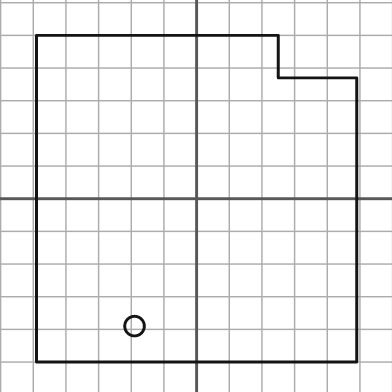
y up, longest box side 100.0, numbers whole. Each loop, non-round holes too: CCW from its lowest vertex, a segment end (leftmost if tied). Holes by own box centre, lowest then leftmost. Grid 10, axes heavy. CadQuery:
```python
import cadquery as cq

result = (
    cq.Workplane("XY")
    .moveTo(-49.0, -50.0)
    .lineTo(49.0, -50.0)
    .lineTo(49.0, 37.0)
    .lineTo(25.0, 37.0)
    .lineTo(25.0, 50.0)
    .lineTo(-49.0, 50.0)
    .close()
    .moveTo(-19.0, -39.0)
    .circle(3.0)
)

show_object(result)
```